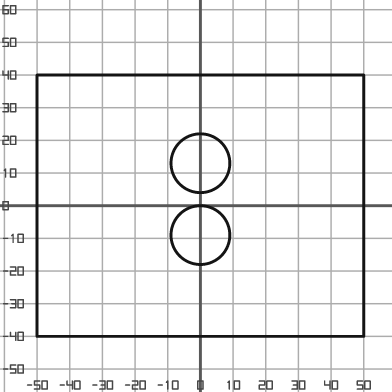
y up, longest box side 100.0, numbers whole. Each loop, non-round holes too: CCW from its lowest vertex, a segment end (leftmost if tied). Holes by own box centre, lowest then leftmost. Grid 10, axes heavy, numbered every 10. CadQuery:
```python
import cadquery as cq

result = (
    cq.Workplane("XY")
    .moveTo(-50.0, -40.0)
    .lineTo(50.0, -40.0)
    .lineTo(50.0, 40.0)
    .lineTo(-50.0, 40.0)
    .close()
    .moveTo(0.0, -9.0)
    .circle(9.0)
    .moveTo(0.0, 13.0)
    .circle(9.0)
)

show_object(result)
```